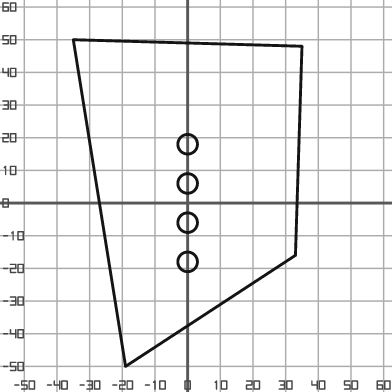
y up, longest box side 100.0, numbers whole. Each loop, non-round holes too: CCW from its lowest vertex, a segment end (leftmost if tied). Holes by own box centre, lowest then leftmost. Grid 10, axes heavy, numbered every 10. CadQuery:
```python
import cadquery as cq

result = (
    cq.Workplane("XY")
    .moveTo(-19.0, -50.0)
    .lineTo(33.0, -16.0)
    .lineTo(35.0, 48.0)
    .lineTo(-35.0, 50.0)
    .close()
    .moveTo(0.0, -18.0)
    .circle(3.0)
    .moveTo(0.0, -6.0)
    .circle(3.0)
    .moveTo(0.0, 6.0)
    .circle(3.0)
    .moveTo(0.0, 18.0)
    .circle(3.0)
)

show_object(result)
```